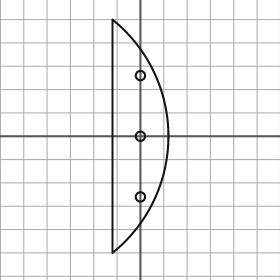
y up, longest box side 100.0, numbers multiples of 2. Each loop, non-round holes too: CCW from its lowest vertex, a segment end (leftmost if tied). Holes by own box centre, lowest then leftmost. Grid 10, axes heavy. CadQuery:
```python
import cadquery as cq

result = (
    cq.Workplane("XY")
    .moveTo(-12.0, -50.0)
    .threePointArc((12.0, 0.0), (-12.0, 50.0))
    .close()
    .moveTo(0.0, -26.0)
    .circle(2.0)
    .moveTo(0.0, 0.0)
    .circle(2.0)
    .moveTo(0.0, 26.0)
    .circle(2.0)
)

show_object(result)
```